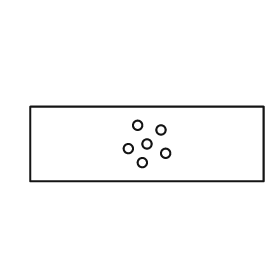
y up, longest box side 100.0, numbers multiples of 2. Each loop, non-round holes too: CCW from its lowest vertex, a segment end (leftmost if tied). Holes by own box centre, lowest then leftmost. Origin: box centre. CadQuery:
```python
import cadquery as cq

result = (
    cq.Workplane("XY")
    .moveTo(-50.0, -16.0)
    .lineTo(50.0, -16.0)
    .lineTo(50.0, 16.0)
    .lineTo(-50.0, 16.0)
    .close()
    .moveTo(-2.0, -8.0)
    .circle(2.0)
    .moveTo(8.0, -4.0)
    .circle(2.0)
    .moveTo(-8.0, -2.0)
    .circle(2.0)
    .moveTo(0.0, 0.0)
    .circle(2.0)
    .moveTo(6.0, 6.0)
    .circle(2.0)
    .moveTo(-4.0, 8.0)
    .circle(2.0)
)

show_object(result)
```